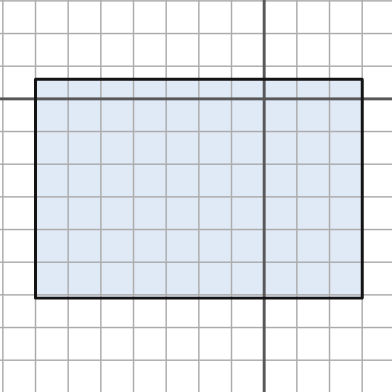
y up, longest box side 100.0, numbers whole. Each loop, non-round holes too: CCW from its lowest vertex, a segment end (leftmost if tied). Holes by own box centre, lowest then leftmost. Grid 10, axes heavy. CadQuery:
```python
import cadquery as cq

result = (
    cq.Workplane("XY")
    .moveTo(-70.0, -61.0)
    .lineTo(30.0, -61.0)
    .lineTo(30.0, 6.0)
    .lineTo(-70.0, 6.0)
    .close()
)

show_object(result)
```